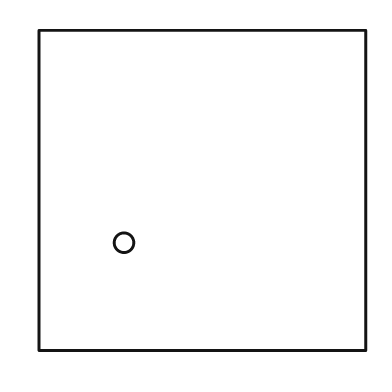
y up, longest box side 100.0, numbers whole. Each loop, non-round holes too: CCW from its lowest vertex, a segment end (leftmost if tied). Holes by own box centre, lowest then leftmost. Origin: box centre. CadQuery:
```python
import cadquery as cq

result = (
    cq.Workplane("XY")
    .moveTo(-50.0, -49.0)
    .lineTo(50.0, -49.0)
    .lineTo(50.0, 49.0)
    .lineTo(-50.0, 49.0)
    .close()
    .moveTo(-24.0, -16.0)
    .circle(3.0)
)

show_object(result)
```